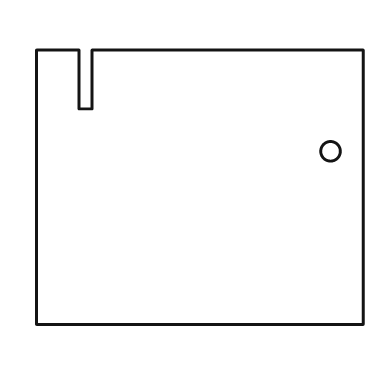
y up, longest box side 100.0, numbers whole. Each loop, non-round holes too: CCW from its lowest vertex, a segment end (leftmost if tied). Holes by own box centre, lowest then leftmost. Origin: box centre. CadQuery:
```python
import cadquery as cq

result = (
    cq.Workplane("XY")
    .moveTo(-50.0, -42.0)
    .lineTo(50.0, -42.0)
    .lineTo(50.0, 42.0)
    .lineTo(-33.0, 42.0)
    .lineTo(-33.0, 24.0)
    .lineTo(-37.0, 24.0)
    .lineTo(-37.0, 42.0)
    .lineTo(-50.0, 42.0)
    .close()
    .moveTo(40.0, 11.0)
    .circle(3.0)
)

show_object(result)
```